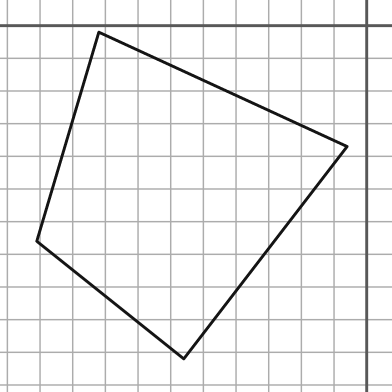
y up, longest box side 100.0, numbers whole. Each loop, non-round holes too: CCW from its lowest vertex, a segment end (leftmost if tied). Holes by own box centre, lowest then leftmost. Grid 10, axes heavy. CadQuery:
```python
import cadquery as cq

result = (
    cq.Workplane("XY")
    .moveTo(-56.0, -102.0)
    .lineTo(-6.0, -37.0)
    .lineTo(-82.0, -2.0)
    .lineTo(-101.0, -66.0)
    .close()
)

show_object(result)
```